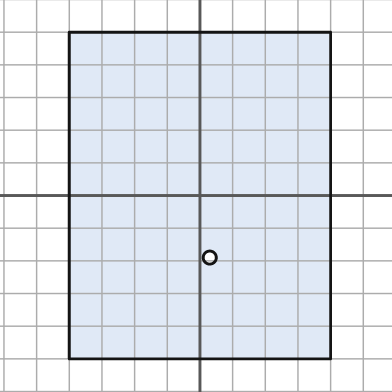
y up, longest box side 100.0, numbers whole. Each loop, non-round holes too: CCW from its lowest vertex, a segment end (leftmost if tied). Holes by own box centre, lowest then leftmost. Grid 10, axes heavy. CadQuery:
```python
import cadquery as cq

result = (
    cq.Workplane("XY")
    .moveTo(-40.0, -50.0)
    .lineTo(40.0, -50.0)
    .lineTo(40.0, 50.0)
    .lineTo(-40.0, 50.0)
    .close()
    .moveTo(3.0, -19.0)
    .circle(2.0)
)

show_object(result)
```